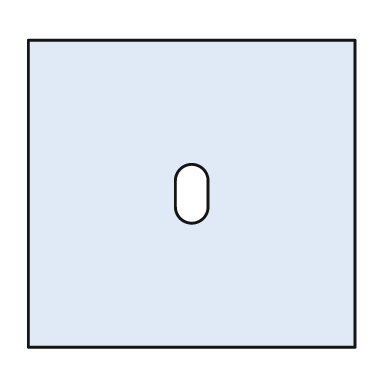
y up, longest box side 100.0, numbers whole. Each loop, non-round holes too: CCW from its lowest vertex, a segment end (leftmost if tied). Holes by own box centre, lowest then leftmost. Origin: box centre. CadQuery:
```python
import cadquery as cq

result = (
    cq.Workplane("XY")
    .moveTo(-50.0, -47.0)
    .lineTo(50.0, -47.0)
    .lineTo(50.0, 47.0)
    .lineTo(-50.0, 47.0)
    .close()
    .moveTo(-5.0, -4.0)
    .threePointArc((0.0, -9.0), (5.0, -4.0))
    .lineTo(5.0, 4.0)
    .threePointArc((0.0, 9.0), (-5.0, 4.0))
    .close()
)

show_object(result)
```